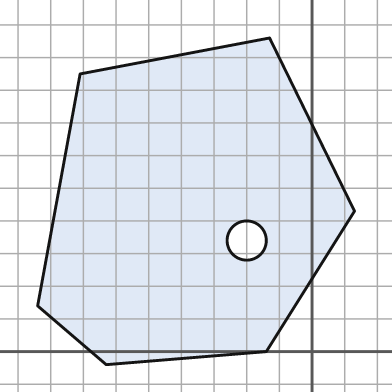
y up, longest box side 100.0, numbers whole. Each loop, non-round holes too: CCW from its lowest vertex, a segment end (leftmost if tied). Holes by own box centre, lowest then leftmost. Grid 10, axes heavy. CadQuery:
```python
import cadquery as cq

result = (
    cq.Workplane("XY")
    .moveTo(-63.0, -4.0)
    .lineTo(-14.0, 0.0)
    .lineTo(13.0, 43.0)
    .lineTo(-13.0, 96.0)
    .lineTo(-71.0, 85.0)
    .lineTo(-84.0, 14.0)
    .close()
    .moveTo(-20.0, 34.0)
    .circle(6.0)
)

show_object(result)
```